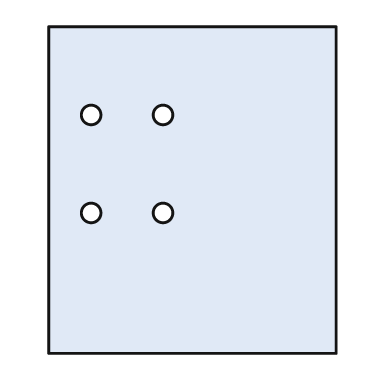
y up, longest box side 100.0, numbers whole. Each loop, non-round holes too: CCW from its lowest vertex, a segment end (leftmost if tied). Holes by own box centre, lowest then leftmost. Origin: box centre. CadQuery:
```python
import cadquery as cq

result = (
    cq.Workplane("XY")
    .moveTo(-44.0, -50.0)
    .lineTo(44.0, -50.0)
    .lineTo(44.0, 50.0)
    .lineTo(-44.0, 50.0)
    .close()
    .moveTo(-31.0, -7.0)
    .circle(3.0)
    .moveTo(-9.0, -7.0)
    .circle(3.0)
    .moveTo(-31.0, 23.0)
    .circle(3.0)
    .moveTo(-9.0, 23.0)
    .circle(3.0)
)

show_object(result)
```